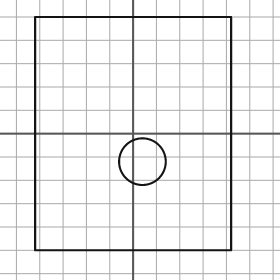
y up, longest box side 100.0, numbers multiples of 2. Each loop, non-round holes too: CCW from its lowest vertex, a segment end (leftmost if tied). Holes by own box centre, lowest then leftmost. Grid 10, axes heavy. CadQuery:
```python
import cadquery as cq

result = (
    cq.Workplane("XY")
    .moveTo(-42.0, -50.0)
    .lineTo(42.0, -50.0)
    .lineTo(42.0, 50.0)
    .lineTo(-42.0, 50.0)
    .close()
    .moveTo(4.0, -12.0)
    .circle(10.0)
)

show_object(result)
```